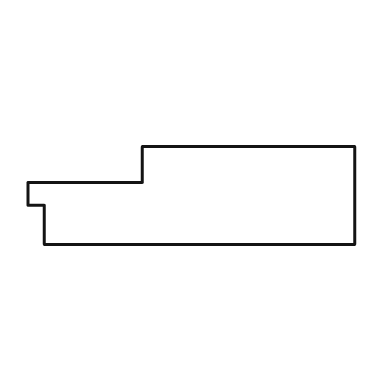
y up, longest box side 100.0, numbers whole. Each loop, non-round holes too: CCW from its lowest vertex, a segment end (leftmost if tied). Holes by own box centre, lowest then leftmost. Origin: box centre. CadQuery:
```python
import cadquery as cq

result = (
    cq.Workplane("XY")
    .moveTo(-45.0, -15.0)
    .lineTo(50.0, -15.0)
    .lineTo(50.0, 15.0)
    .lineTo(-15.0, 15.0)
    .lineTo(-15.0, 4.0)
    .lineTo(-50.0, 4.0)
    .lineTo(-50.0, -3.0)
    .lineTo(-45.0, -3.0)
    .close()
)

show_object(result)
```